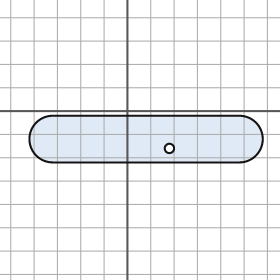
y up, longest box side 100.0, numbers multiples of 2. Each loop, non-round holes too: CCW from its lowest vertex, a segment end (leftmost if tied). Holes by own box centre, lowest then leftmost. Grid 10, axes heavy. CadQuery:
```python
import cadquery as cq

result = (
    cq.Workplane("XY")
    .moveTo(-32.0, -22.0)
    .lineTo(48.0, -22.0)
    .threePointArc((58.0, -12.0), (48.0, -2.0))
    .lineTo(-32.0, -2.0)
    .threePointArc((-42.0, -12.0), (-32.0, -22.0))
    .close()
    .moveTo(18.0, -16.0)
    .circle(2.0)
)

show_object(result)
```